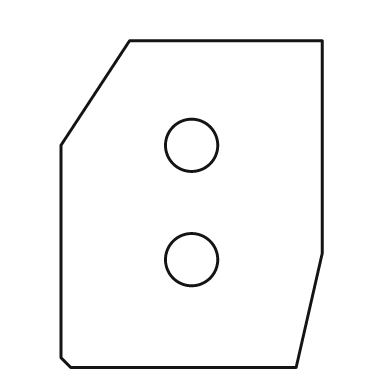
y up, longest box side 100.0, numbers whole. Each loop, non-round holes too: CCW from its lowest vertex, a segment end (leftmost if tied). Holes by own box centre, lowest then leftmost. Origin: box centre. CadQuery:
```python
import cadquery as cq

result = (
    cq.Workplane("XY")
    .moveTo(-37.0, -50.0)
    .lineTo(32.0, -50.0)
    .lineTo(40.0, -15.0)
    .lineTo(40.0, 50.0)
    .lineTo(-19.0, 50.0)
    .lineTo(-40.0, 18.0)
    .lineTo(-40.0, -47.0)
    .close()
    .moveTo(0.0, -17.0)
    .circle(8.0)
    .moveTo(0.0, 18.0)
    .circle(8.0)
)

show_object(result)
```